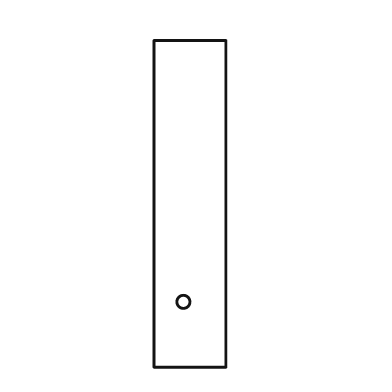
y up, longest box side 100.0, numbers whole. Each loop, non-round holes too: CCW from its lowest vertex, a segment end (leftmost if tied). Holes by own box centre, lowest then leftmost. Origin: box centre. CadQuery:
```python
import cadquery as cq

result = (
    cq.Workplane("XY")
    .moveTo(-11.0, -50.0)
    .lineTo(11.0, -50.0)
    .lineTo(11.0, 50.0)
    .lineTo(-11.0, 50.0)
    .close()
    .moveTo(-2.0, -30.0)
    .circle(2.0)
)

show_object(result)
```